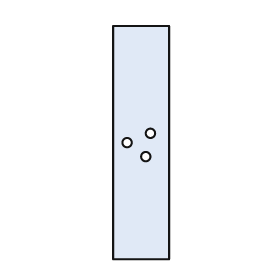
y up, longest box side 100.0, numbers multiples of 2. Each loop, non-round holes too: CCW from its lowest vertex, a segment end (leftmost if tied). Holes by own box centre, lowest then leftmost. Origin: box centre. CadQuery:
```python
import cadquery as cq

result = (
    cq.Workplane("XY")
    .moveTo(-12.0, -50.0)
    .lineTo(12.0, -50.0)
    .lineTo(12.0, 50.0)
    .lineTo(-12.0, 50.0)
    .close()
    .moveTo(2.0, -6.0)
    .circle(2.0)
    .moveTo(-6.0, 0.0)
    .circle(2.0)
    .moveTo(4.0, 4.0)
    .circle(2.0)
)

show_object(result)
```